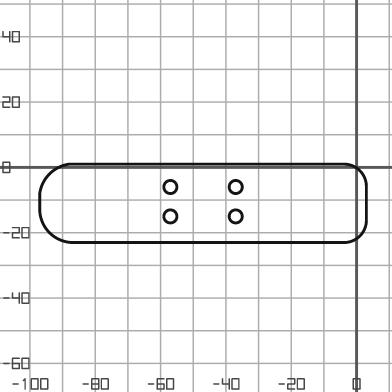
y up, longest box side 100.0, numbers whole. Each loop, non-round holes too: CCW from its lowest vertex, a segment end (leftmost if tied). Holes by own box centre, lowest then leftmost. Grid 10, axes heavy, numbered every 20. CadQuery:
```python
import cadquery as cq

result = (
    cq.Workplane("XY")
    .moveTo(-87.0, -23.0)
    .lineTo(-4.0, -23.0)
    .threePointArc((1.0, -21.0), (3.0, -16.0))
    .lineTo(3.0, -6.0)
    .threePointArc((1.0, -1.0), (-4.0, 1.0))
    .lineTo(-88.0, 1.0)
    .threePointArc((-94.0, -2.0), (-97.0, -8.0))
    .lineTo(-97.0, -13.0)
    .threePointArc((-94.0, -20.0), (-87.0, -23.0))
    .close()
    .moveTo(-57.0, -15.0)
    .circle(2.0)
    .moveTo(-37.0, -15.0)
    .circle(2.0)
    .moveTo(-57.0, -6.0)
    .circle(2.0)
    .moveTo(-37.0, -6.0)
    .circle(2.0)
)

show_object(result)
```